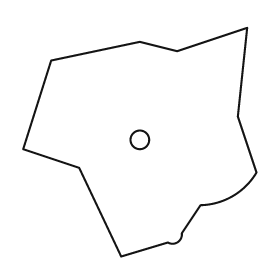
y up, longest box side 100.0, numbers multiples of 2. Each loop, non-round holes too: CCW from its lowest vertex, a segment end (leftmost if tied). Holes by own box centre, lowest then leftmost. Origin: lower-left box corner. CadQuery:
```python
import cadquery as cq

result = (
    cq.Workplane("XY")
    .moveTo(42.0, 0.0)
    .lineTo(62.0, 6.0)
    .threePointArc((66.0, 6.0), (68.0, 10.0))
    .lineTo(76.0, 22.0)
    .threePointArc((90.0, 26.0), (100.0, 36.0))
    .lineTo(92.0, 60.0)
    .lineTo(96.0, 98.0)
    .lineTo(66.0, 88.0)
    .lineTo(50.0, 92.0)
    .lineTo(12.0, 84.0)
    .lineTo(0.0, 46.0)
    .lineTo(24.0, 38.0)
    .close()
    .moveTo(50.0, 50.0)
    .circle(4.0)
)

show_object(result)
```